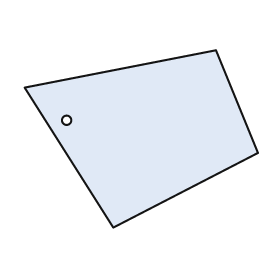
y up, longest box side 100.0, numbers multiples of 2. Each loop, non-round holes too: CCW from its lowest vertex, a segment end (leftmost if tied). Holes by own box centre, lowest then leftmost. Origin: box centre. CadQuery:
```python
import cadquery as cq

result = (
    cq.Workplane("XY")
    .moveTo(-12.0, -38.0)
    .lineTo(50.0, -6.0)
    .lineTo(32.0, 38.0)
    .lineTo(-50.0, 22.0)
    .close()
    .moveTo(-32.0, 8.0)
    .circle(2.0)
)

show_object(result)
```